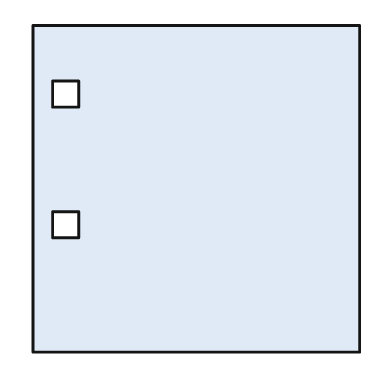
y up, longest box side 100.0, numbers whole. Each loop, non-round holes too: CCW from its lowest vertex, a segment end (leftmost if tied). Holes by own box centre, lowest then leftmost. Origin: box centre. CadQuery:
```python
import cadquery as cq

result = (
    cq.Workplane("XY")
    .moveTo(-50.0, -50.0)
    .lineTo(50.0, -50.0)
    .lineTo(50.0, 50.0)
    .lineTo(-50.0, 50.0)
    .close()
    .moveTo(-44.0, -15.0)
    .lineTo(-36.0, -15.0)
    .lineTo(-36.0, -7.0)
    .lineTo(-44.0, -7.0)
    .close()
    .moveTo(-44.0, 25.0)
    .lineTo(-36.0, 25.0)
    .lineTo(-36.0, 33.0)
    .lineTo(-44.0, 33.0)
    .close()
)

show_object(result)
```